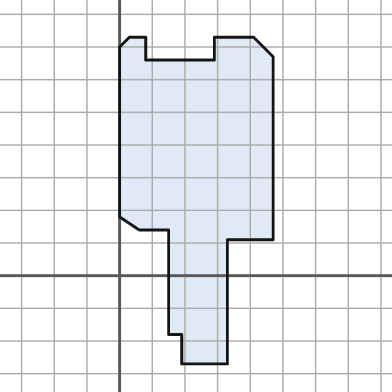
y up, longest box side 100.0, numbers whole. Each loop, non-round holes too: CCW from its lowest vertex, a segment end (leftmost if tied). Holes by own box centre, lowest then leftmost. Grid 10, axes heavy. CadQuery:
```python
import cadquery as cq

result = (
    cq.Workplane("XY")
    .moveTo(19.0, -27.0)
    .lineTo(33.0, -27.0)
    .lineTo(33.0, 11.0)
    .lineTo(47.0, 11.0)
    .lineTo(47.0, 67.0)
    .lineTo(41.0, 73.0)
    .lineTo(29.0, 73.0)
    .lineTo(29.0, 66.0)
    .lineTo(8.0, 66.0)
    .lineTo(8.0, 73.0)
    .lineTo(3.0, 73.0)
    .lineTo(0.0, 70.0)
    .lineTo(0.0, 18.0)
    .lineTo(6.0, 14.0)
    .lineTo(15.0, 14.0)
    .lineTo(15.0, -18.0)
    .lineTo(19.0, -18.0)
    .close()
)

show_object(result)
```